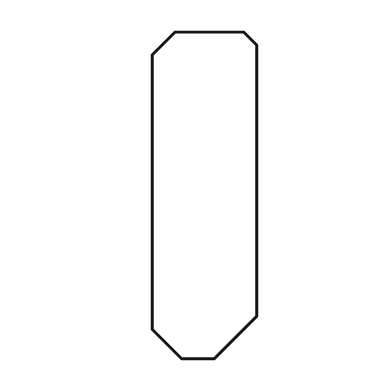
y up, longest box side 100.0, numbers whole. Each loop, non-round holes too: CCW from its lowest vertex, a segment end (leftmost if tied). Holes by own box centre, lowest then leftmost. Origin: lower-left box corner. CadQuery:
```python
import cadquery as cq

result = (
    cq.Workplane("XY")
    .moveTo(9.0, 0.0)
    .lineTo(19.0, 0.0)
    .lineTo(32.0, 13.0)
    .lineTo(32.0, 96.0)
    .lineTo(28.0, 100.0)
    .lineTo(7.0, 100.0)
    .lineTo(0.0, 93.0)
    .lineTo(0.0, 9.0)
    .close()
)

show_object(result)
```